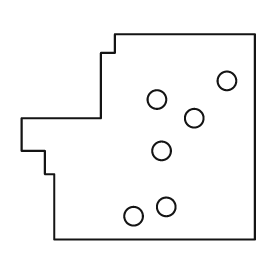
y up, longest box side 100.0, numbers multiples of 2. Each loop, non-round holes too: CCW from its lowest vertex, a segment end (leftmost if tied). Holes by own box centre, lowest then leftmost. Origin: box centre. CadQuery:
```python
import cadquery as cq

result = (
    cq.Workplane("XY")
    .moveTo(-36.0, -44.0)
    .lineTo(50.0, -44.0)
    .lineTo(50.0, 44.0)
    .lineTo(-10.0, 44.0)
    .lineTo(-10.0, 36.0)
    .lineTo(-16.0, 36.0)
    .lineTo(-16.0, 8.0)
    .lineTo(-50.0, 8.0)
    .lineTo(-50.0, -6.0)
    .lineTo(-40.0, -6.0)
    .lineTo(-40.0, -16.0)
    .lineTo(-36.0, -16.0)
    .close()
    .moveTo(-2.0, -34.0)
    .circle(4.0)
    .moveTo(12.0, -30.0)
    .circle(4.0)
    .moveTo(10.0, -6.0)
    .circle(4.0)
    .moveTo(24.0, 8.0)
    .circle(4.0)
    .moveTo(8.0, 16.0)
    .circle(4.0)
    .moveTo(38.0, 24.0)
    .circle(4.0)
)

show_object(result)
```